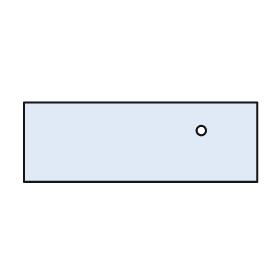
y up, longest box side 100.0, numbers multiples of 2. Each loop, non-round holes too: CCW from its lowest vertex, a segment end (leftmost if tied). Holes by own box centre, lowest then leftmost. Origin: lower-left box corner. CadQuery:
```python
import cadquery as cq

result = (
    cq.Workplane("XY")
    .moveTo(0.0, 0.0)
    .lineTo(100.0, 0.0)
    .lineTo(100.0, 34.0)
    .lineTo(0.0, 34.0)
    .close()
    .moveTo(76.0, 22.0)
    .circle(2.0)
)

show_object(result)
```